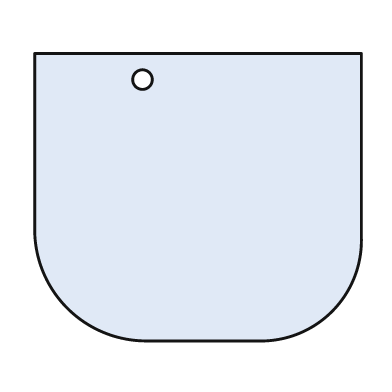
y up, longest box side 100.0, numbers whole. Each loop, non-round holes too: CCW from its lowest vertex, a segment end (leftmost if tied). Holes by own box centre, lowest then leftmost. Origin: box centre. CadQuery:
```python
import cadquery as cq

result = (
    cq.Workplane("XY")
    .moveTo(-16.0, -44.0)
    .lineTo(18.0, -44.0)
    .threePointArc((41.0, -35.0), (50.0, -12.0))
    .lineTo(50.0, 44.0)
    .lineTo(-50.0, 44.0)
    .lineTo(-50.0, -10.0)
    .threePointArc((-40.0, -34.0), (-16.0, -44.0))
    .close()
    .moveTo(-17.0, 36.0)
    .circle(3.0)
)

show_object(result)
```